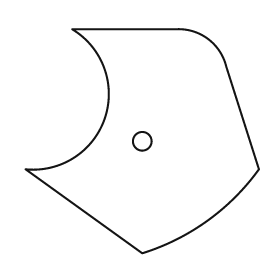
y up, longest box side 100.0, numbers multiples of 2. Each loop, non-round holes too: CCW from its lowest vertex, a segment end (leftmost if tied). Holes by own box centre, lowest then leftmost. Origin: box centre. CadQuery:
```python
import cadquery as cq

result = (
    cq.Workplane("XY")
    .moveTo(0.0, -48.0)
    .threePointArc((28.0, -34.0), (50.0, -12.0))
    .lineTo(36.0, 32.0)
    .threePointArc((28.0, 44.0), (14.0, 48.0))
    .lineTo(-30.0, 48.0)
    .threePointArc((-16.0, 10.0), (-50.0, -12.0))
    .close()
    .moveTo(0.0, 0.0)
    .circle(4.0)
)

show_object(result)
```